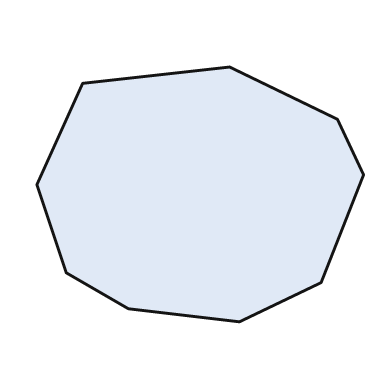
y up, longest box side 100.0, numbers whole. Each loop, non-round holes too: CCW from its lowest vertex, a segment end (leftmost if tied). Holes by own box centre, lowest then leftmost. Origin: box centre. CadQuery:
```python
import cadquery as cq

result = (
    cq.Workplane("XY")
    .moveTo(12.0, -39.0)
    .lineTo(37.0, -27.0)
    .lineTo(50.0, 6.0)
    .lineTo(42.0, 23.0)
    .lineTo(9.0, 39.0)
    .lineTo(-36.0, 34.0)
    .lineTo(-50.0, 3.0)
    .lineTo(-41.0, -24.0)
    .lineTo(-22.0, -35.0)
    .close()
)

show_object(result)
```